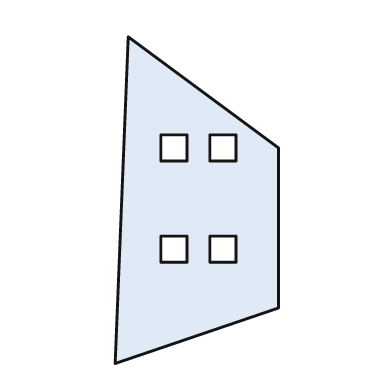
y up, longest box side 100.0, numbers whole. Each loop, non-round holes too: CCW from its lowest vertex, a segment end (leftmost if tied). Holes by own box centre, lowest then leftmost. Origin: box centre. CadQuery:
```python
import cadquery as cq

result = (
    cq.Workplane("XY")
    .moveTo(-25.0, -50.0)
    .lineTo(25.0, -33.0)
    .lineTo(25.0, 16.0)
    .lineTo(-21.0, 50.0)
    .close()
    .moveTo(-11.0, -19.0)
    .lineTo(-3.0, -19.0)
    .lineTo(-3.0, -11.0)
    .lineTo(-11.0, -11.0)
    .close()
    .moveTo(4.0, -19.0)
    .lineTo(12.0, -19.0)
    .lineTo(12.0, -11.0)
    .lineTo(4.0, -11.0)
    .close()
    .moveTo(-11.0, 12.0)
    .lineTo(-3.0, 12.0)
    .lineTo(-3.0, 20.0)
    .lineTo(-11.0, 20.0)
    .close()
    .moveTo(4.0, 12.0)
    .lineTo(12.0, 12.0)
    .lineTo(12.0, 20.0)
    .lineTo(4.0, 20.0)
    .close()
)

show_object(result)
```